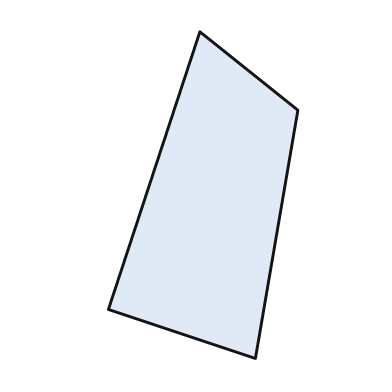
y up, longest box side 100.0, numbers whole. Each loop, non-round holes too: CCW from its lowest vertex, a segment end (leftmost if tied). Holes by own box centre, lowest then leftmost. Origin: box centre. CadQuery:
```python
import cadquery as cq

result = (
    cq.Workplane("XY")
    .moveTo(16.0, -50.0)
    .lineTo(29.0, 26.0)
    .lineTo(-1.0, 50.0)
    .lineTo(-29.0, -35.0)
    .close()
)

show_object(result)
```